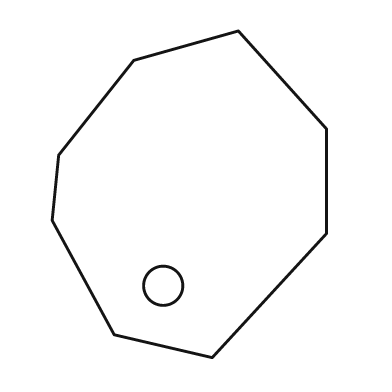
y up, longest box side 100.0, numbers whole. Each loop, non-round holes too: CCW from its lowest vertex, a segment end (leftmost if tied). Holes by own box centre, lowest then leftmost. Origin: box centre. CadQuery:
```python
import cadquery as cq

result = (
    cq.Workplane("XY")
    .moveTo(7.0, -50.0)
    .lineTo(42.0, -12.0)
    .lineTo(42.0, 20.0)
    .lineTo(15.0, 50.0)
    .lineTo(-17.0, 41.0)
    .lineTo(-40.0, 12.0)
    .lineTo(-42.0, -8.0)
    .lineTo(-23.0, -43.0)
    .close()
    .moveTo(-8.0, -28.0)
    .circle(6.0)
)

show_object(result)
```